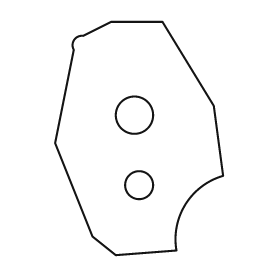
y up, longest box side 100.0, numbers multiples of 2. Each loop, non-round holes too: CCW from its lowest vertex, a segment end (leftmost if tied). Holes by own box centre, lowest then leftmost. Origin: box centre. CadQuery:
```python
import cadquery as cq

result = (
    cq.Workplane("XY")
    .moveTo(-10.0, -50.0)
    .lineTo(16.0, -48.0)
    .threePointArc((20.0, -28.0), (36.0, -16.0))
    .lineTo(32.0, 14.0)
    .lineTo(10.0, 50.0)
    .lineTo(-12.0, 50.0)
    .lineTo(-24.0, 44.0)
    .threePointArc((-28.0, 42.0), (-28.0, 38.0))
    .lineTo(-36.0, -2.0)
    .lineTo(-20.0, -42.0)
    .close()
    .moveTo(0.0, -20.0)
    .circle(6.0)
    .moveTo(-2.0, 10.0)
    .circle(8.0)
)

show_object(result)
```